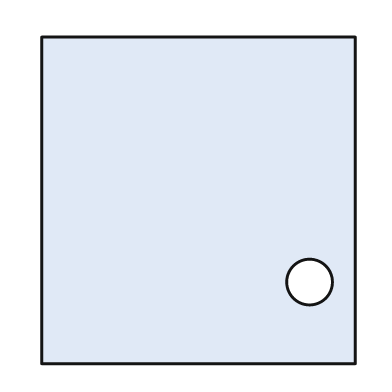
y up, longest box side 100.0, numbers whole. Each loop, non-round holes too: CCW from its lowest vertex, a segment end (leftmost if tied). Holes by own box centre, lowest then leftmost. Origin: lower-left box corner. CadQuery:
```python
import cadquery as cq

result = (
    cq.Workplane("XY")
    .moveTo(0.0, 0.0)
    .lineTo(96.0, 0.0)
    .lineTo(96.0, 100.0)
    .lineTo(0.0, 100.0)
    .close()
    .moveTo(82.0, 25.0)
    .circle(7.0)
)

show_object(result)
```